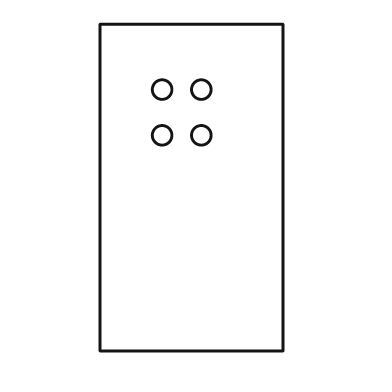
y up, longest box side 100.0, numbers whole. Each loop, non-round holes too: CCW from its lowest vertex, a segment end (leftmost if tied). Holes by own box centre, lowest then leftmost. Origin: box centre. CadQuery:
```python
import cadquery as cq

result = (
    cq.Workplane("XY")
    .moveTo(-28.0, -50.0)
    .lineTo(28.0, -50.0)
    .lineTo(28.0, 50.0)
    .lineTo(-28.0, 50.0)
    .close()
    .moveTo(-9.0, 16.0)
    .circle(3.0)
    .moveTo(3.0, 16.0)
    .circle(3.0)
    .moveTo(-9.0, 30.0)
    .circle(3.0)
    .moveTo(3.0, 30.0)
    .circle(3.0)
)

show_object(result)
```